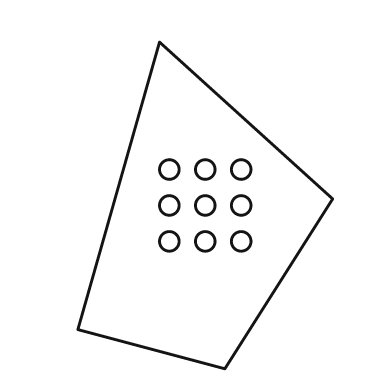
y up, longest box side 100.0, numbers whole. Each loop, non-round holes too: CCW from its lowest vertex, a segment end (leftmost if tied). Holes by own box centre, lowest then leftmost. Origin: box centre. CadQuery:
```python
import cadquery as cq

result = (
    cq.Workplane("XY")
    .moveTo(6.0, -50.0)
    .lineTo(39.0, 2.0)
    .lineTo(-14.0, 50.0)
    .lineTo(-39.0, -38.0)
    .close()
    .moveTo(-11.0, -11.0)
    .circle(3.0)
    .moveTo(0.0, -11.0)
    .circle(3.0)
    .moveTo(11.0, -11.0)
    .circle(3.0)
    .moveTo(-11.0, 0.0)
    .circle(3.0)
    .moveTo(0.0, 0.0)
    .circle(3.0)
    .moveTo(11.0, 0.0)
    .circle(3.0)
    .moveTo(-11.0, 11.0)
    .circle(3.0)
    .moveTo(0.0, 11.0)
    .circle(3.0)
    .moveTo(11.0, 11.0)
    .circle(3.0)
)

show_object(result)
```